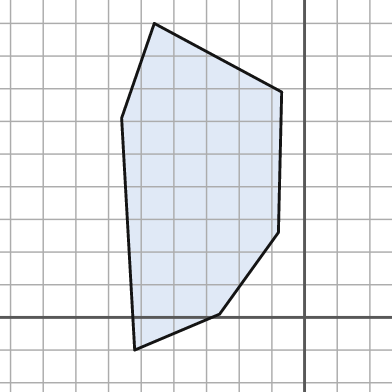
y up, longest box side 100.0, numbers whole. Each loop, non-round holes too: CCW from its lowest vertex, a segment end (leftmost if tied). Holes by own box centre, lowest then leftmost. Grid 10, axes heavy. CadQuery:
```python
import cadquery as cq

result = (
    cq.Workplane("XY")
    .moveTo(-52.0, -10.0)
    .lineTo(-26.0, 1.0)
    .lineTo(-8.0, 26.0)
    .lineTo(-7.0, 69.0)
    .lineTo(-46.0, 90.0)
    .lineTo(-56.0, 61.0)
    .close()
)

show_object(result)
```